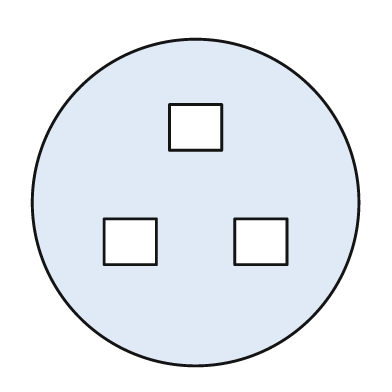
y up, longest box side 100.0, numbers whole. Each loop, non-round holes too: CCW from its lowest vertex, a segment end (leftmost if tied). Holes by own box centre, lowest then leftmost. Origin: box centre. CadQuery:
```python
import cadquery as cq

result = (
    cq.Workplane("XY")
    .moveTo(0.0, 0.0)
    .circle(50.0)
    .moveTo(-28.0, -19.0)
    .lineTo(-12.0, -19.0)
    .lineTo(-12.0, -5.0)
    .lineTo(-28.0, -5.0)
    .close()
    .moveTo(12.0, -19.0)
    .lineTo(28.0, -19.0)
    .lineTo(28.0, -5.0)
    .lineTo(12.0, -5.0)
    .close()
    .moveTo(-8.0, 16.0)
    .lineTo(8.0, 16.0)
    .lineTo(8.0, 30.0)
    .lineTo(-8.0, 30.0)
    .close()
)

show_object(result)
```